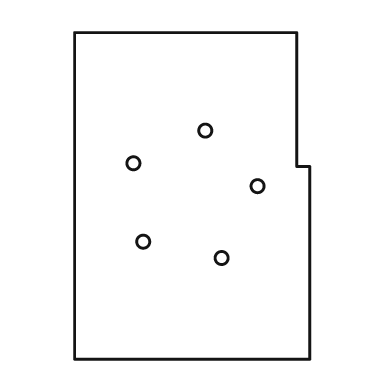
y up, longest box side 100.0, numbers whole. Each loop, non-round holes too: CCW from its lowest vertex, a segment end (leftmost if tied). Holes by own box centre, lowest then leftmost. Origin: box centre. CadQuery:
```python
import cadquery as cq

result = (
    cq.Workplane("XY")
    .moveTo(-36.0, -50.0)
    .lineTo(36.0, -50.0)
    .lineTo(36.0, 9.0)
    .lineTo(32.0, 9.0)
    .lineTo(32.0, 50.0)
    .lineTo(-36.0, 50.0)
    .close()
    .moveTo(9.0, -19.0)
    .circle(2.0)
    .moveTo(-15.0, -14.0)
    .circle(2.0)
    .moveTo(20.0, 3.0)
    .circle(2.0)
    .moveTo(-18.0, 10.0)
    .circle(2.0)
    .moveTo(4.0, 20.0)
    .circle(2.0)
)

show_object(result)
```